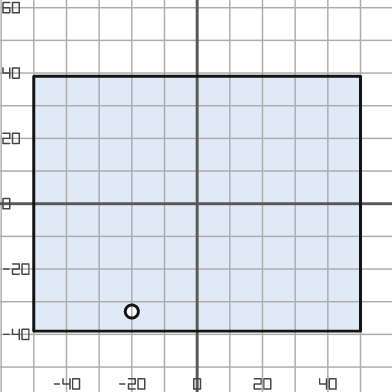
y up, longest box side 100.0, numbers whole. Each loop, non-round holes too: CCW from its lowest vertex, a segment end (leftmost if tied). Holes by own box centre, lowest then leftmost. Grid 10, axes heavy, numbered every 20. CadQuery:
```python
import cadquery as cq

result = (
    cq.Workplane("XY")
    .moveTo(-50.0, -39.0)
    .lineTo(50.0, -39.0)
    .lineTo(50.0, 39.0)
    .lineTo(-50.0, 39.0)
    .close()
    .moveTo(-20.0, -33.0)
    .circle(2.0)
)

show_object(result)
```